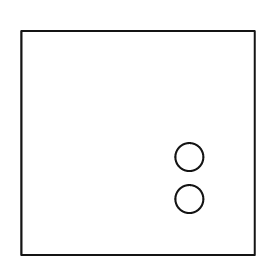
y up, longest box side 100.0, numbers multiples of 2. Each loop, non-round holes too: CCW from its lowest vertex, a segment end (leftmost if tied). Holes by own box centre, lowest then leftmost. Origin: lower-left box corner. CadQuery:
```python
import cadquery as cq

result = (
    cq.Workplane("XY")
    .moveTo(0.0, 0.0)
    .lineTo(100.0, 0.0)
    .lineTo(100.0, 96.0)
    .lineTo(0.0, 96.0)
    .close()
    .moveTo(72.0, 24.0)
    .circle(6.0)
    .moveTo(72.0, 42.0)
    .circle(6.0)
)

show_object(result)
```